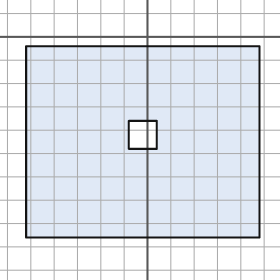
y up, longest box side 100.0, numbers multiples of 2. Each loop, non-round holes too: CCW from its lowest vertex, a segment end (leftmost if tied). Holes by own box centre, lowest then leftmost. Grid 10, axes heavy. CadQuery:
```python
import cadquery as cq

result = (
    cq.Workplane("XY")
    .moveTo(-52.0, -86.0)
    .lineTo(48.0, -86.0)
    .lineTo(48.0, -4.0)
    .lineTo(-52.0, -4.0)
    .close()
    .moveTo(-8.0, -48.0)
    .lineTo(4.0, -48.0)
    .lineTo(4.0, -36.0)
    .lineTo(-8.0, -36.0)
    .close()
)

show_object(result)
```